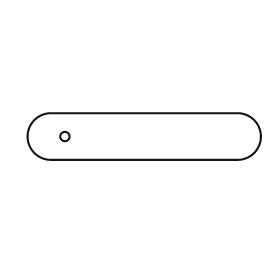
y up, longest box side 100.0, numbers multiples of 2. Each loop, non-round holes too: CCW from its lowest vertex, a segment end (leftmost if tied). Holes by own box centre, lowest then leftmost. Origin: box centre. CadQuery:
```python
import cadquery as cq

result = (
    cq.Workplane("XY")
    .moveTo(-40.0, -10.0)
    .lineTo(40.0, -10.0)
    .threePointArc((50.0, 0.0), (40.0, 10.0))
    .lineTo(-40.0, 10.0)
    .threePointArc((-50.0, 0.0), (-40.0, -10.0))
    .close()
    .moveTo(-34.0, 0.0)
    .circle(2.0)
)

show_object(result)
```